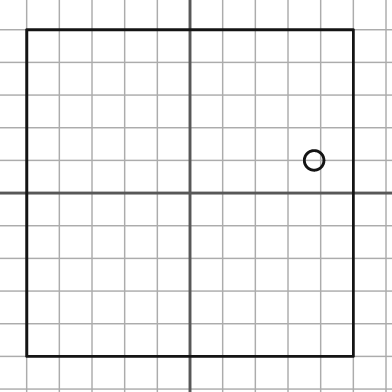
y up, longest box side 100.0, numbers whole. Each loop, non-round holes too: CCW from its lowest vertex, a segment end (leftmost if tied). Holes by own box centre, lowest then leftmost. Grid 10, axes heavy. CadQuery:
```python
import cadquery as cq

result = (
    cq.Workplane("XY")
    .moveTo(-50.0, -50.0)
    .lineTo(50.0, -50.0)
    .lineTo(50.0, 50.0)
    .lineTo(-50.0, 50.0)
    .close()
    .moveTo(38.0, 10.0)
    .circle(3.0)
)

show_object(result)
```